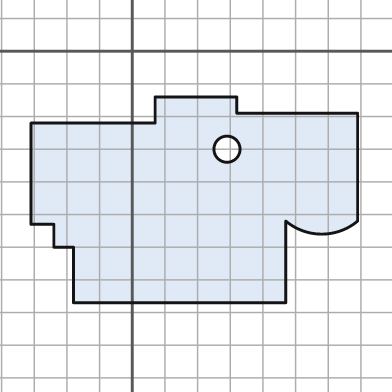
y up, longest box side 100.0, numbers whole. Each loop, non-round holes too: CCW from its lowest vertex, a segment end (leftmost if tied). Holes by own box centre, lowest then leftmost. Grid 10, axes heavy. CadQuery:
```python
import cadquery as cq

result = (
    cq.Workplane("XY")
    .moveTo(-18.0, -77.0)
    .lineTo(47.0, -77.0)
    .lineTo(47.0, -52.0)
    .threePointArc((58.0, -56.0), (69.0, -52.0))
    .lineTo(69.0, -19.0)
    .lineTo(32.0, -19.0)
    .lineTo(32.0, -14.0)
    .lineTo(7.0, -14.0)
    .lineTo(7.0, -22.0)
    .lineTo(-31.0, -22.0)
    .lineTo(-31.0, -53.0)
    .lineTo(-24.0, -53.0)
    .lineTo(-24.0, -60.0)
    .lineTo(-18.0, -60.0)
    .close()
    .moveTo(29.0, -30.0)
    .circle(4.0)
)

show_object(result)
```